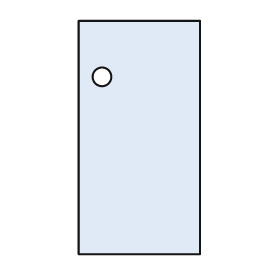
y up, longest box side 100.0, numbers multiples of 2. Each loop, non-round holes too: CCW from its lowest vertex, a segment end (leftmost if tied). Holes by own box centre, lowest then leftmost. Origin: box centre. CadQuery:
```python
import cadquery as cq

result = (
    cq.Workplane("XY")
    .moveTo(-26.0, -50.0)
    .lineTo(26.0, -50.0)
    .lineTo(26.0, 50.0)
    .lineTo(-26.0, 50.0)
    .close()
    .moveTo(-16.0, 26.0)
    .circle(4.0)
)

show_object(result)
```